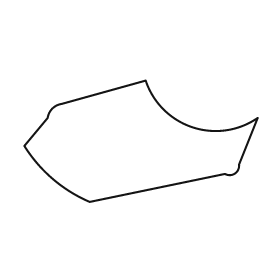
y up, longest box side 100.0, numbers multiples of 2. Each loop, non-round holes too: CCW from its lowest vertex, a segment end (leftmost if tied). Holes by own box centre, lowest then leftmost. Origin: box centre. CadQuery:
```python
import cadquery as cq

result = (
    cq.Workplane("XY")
    .moveTo(-22.0, -26.0)
    .lineTo(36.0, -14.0)
    .threePointArc((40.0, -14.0), (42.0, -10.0))
    .lineTo(50.0, 10.0)
    .threePointArc((22.0, 6.0), (2.0, 26.0))
    .lineTo(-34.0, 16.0)
    .threePointArc((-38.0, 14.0), (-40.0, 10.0))
    .lineTo(-50.0, -2.0)
    .threePointArc((-38.0, -16.0), (-22.0, -26.0))
    .close()
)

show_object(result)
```